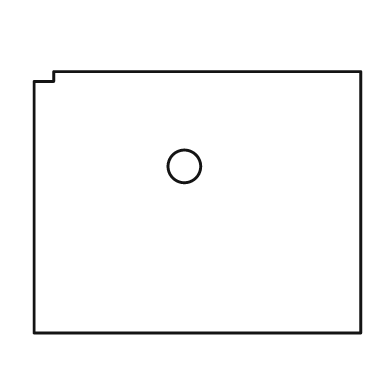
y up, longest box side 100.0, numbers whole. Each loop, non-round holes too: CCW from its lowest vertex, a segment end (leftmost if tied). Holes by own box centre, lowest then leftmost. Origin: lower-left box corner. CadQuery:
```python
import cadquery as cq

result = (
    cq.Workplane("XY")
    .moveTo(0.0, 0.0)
    .lineTo(100.0, 0.0)
    .lineTo(100.0, 80.0)
    .lineTo(6.0, 80.0)
    .lineTo(6.0, 77.0)
    .lineTo(0.0, 77.0)
    .close()
    .moveTo(46.0, 51.0)
    .circle(5.0)
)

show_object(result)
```